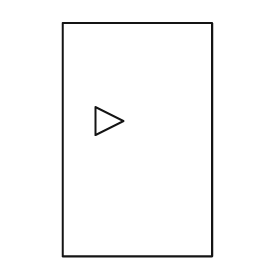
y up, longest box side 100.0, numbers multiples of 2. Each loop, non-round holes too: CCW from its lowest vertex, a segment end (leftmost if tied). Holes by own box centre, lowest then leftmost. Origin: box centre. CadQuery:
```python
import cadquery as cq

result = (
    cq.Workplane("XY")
    .moveTo(-32.0, -50.0)
    .lineTo(32.0, -50.0)
    .lineTo(32.0, 50.0)
    .lineTo(-32.0, 50.0)
    .close()
    .moveTo(-18.0, 2.0)
    .lineTo(-6.0, 8.0)
    .lineTo(-18.0, 14.0)
    .close()
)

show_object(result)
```